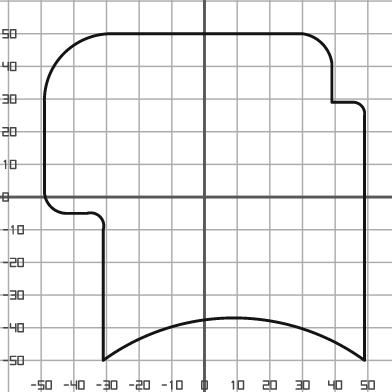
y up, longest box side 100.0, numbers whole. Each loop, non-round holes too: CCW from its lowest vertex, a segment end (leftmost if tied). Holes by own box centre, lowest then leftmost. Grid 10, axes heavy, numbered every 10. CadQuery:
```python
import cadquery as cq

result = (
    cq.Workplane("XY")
    .moveTo(-31.0, -50.0)
    .threePointArc((9.0, -37.0), (49.0, -50.0))
    .lineTo(49.0, 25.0)
    .threePointArc((48.0, 28.0), (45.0, 29.0))
    .lineTo(39.0, 29.0)
    .lineTo(39.0, 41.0)
    .threePointArc((36.0, 47.0), (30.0, 50.0))
    .lineTo(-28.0, 50.0)
    .threePointArc((-43.0, 44.0), (-49.0, 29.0))
    .lineTo(-49.0, 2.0)
    .threePointArc((-47.0, -3.0), (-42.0, -5.0))
    .lineTo(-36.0, -5.0)
    .threePointArc((-32.0, -6.0), (-31.0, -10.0))
    .close()
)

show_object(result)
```